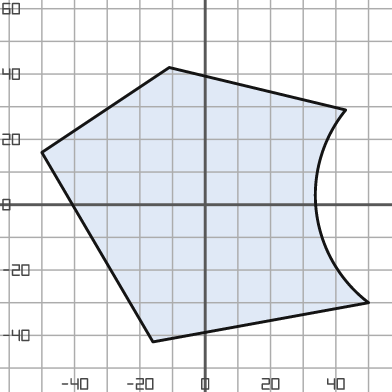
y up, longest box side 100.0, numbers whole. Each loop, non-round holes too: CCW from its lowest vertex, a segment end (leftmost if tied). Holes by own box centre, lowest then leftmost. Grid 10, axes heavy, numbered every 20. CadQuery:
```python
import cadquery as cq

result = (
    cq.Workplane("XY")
    .moveTo(-16.0, -42.0)
    .lineTo(50.0, -30.0)
    .threePointArc((34.0, -2.0), (43.0, 29.0))
    .lineTo(-11.0, 42.0)
    .lineTo(-50.0, 16.0)
    .close()
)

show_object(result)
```